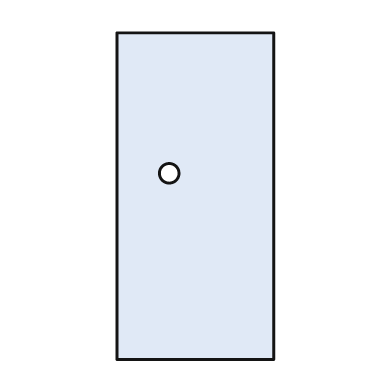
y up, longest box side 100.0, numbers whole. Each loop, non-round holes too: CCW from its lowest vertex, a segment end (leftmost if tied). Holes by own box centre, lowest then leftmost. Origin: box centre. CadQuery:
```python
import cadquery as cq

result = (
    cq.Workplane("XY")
    .moveTo(-24.0, -50.0)
    .lineTo(24.0, -50.0)
    .lineTo(24.0, 50.0)
    .lineTo(-24.0, 50.0)
    .close()
    .moveTo(-8.0, 7.0)
    .circle(3.0)
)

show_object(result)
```